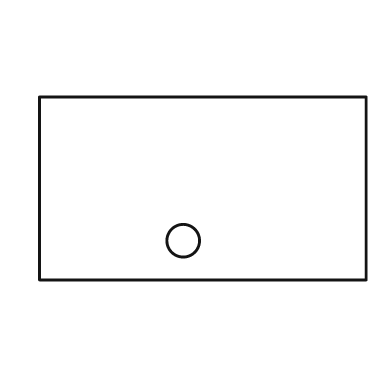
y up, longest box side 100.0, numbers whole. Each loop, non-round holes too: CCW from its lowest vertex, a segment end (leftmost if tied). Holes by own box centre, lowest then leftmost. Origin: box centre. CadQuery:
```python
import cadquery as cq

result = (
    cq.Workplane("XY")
    .moveTo(-50.0, -28.0)
    .lineTo(50.0, -28.0)
    .lineTo(50.0, 28.0)
    .lineTo(-50.0, 28.0)
    .close()
    .moveTo(-6.0, -16.0)
    .circle(5.0)
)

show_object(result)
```